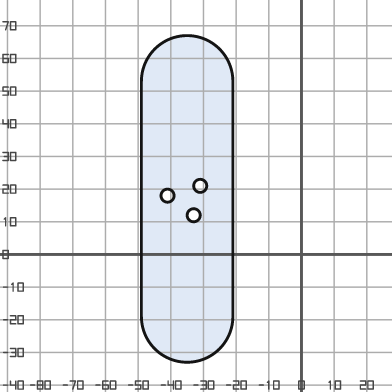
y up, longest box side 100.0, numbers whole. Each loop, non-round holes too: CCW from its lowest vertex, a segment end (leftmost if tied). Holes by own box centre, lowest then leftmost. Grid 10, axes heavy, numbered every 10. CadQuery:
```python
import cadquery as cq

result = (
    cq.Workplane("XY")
    .moveTo(-49.0, -19.0)
    .threePointArc((-35.0, -33.0), (-21.0, -19.0))
    .lineTo(-21.0, 53.0)
    .threePointArc((-35.0, 67.0), (-49.0, 53.0))
    .close()
    .moveTo(-33.0, 12.0)
    .circle(2.0)
    .moveTo(-41.0, 18.0)
    .circle(2.0)
    .moveTo(-31.0, 21.0)
    .circle(2.0)
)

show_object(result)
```